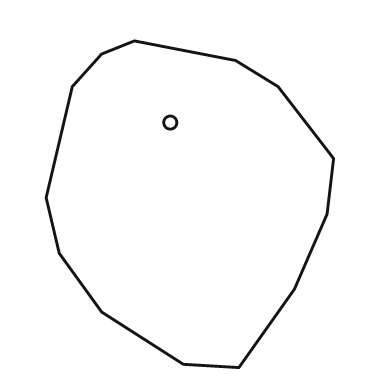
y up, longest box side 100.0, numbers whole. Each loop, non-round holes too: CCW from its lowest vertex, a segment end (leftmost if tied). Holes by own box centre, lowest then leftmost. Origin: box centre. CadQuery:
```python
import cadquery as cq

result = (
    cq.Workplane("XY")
    .moveTo(15.0, -50.0)
    .lineTo(32.0, -26.0)
    .lineTo(42.0, -3.0)
    .lineTo(44.0, 14.0)
    .lineTo(27.0, 36.0)
    .lineTo(14.0, 44.0)
    .lineTo(-17.0, 50.0)
    .lineTo(-27.0, 46.0)
    .lineTo(-36.0, 36.0)
    .lineTo(-44.0, 2.0)
    .lineTo(-40.0, -15.0)
    .lineTo(-27.0, -33.0)
    .lineTo(-2.0, -49.0)
    .close()
    .moveTo(-6.0, 25.0)
    .circle(2.0)
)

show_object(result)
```